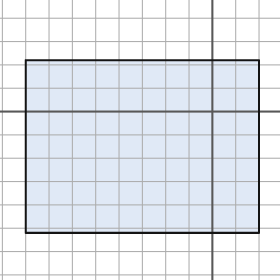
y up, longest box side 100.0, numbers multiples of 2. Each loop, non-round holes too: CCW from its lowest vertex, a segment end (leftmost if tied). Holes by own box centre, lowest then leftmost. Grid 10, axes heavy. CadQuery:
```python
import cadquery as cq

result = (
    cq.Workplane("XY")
    .moveTo(-80.0, -52.0)
    .lineTo(20.0, -52.0)
    .lineTo(20.0, 22.0)
    .lineTo(-80.0, 22.0)
    .close()
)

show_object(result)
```